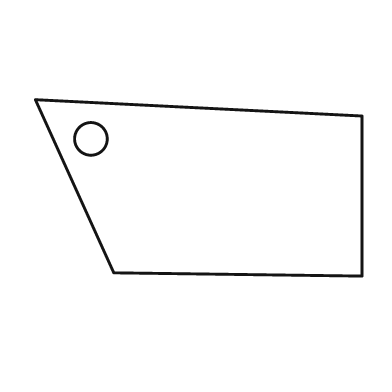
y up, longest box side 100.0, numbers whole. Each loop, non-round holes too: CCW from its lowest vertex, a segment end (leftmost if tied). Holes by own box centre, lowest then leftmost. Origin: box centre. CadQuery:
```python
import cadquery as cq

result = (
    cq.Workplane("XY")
    .moveTo(50.0, -27.0)
    .lineTo(50.0, 22.0)
    .lineTo(-50.0, 27.0)
    .lineTo(-26.0, -26.0)
    .close()
    .moveTo(-33.0, 15.0)
    .circle(5.0)
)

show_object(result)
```